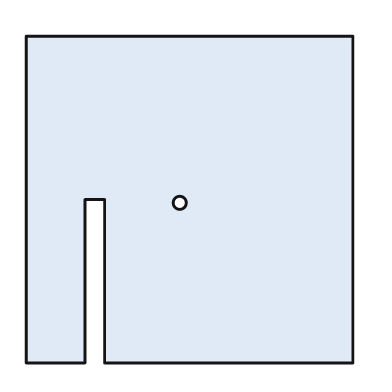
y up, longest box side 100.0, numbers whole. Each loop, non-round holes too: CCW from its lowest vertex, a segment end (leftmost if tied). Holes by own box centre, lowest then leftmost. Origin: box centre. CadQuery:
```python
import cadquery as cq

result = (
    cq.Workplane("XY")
    .moveTo(-50.0, -50.0)
    .lineTo(-32.0, -50.0)
    .lineTo(-32.0, 0.0)
    .lineTo(-26.0, 0.0)
    .lineTo(-26.0, -50.0)
    .lineTo(50.0, -50.0)
    .lineTo(50.0, 50.0)
    .lineTo(-50.0, 50.0)
    .close()
    .moveTo(-3.0, -1.0)
    .circle(2.0)
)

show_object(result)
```